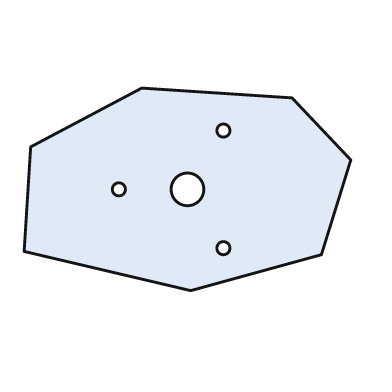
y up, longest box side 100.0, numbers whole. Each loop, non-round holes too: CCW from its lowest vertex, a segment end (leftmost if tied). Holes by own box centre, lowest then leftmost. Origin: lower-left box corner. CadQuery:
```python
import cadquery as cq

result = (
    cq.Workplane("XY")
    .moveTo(51.0, 0.0)
    .lineTo(91.0, 11.0)
    .lineTo(100.0, 40.0)
    .lineTo(82.0, 59.0)
    .lineTo(36.0, 62.0)
    .lineTo(2.0, 44.0)
    .lineTo(0.0, 12.0)
    .close()
    .moveTo(61.0, 13.0)
    .circle(2.0)
    .moveTo(29.0, 31.0)
    .circle(2.0)
    .moveTo(50.0, 31.0)
    .circle(5.0)
    .moveTo(61.0, 49.0)
    .circle(2.0)
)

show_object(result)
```